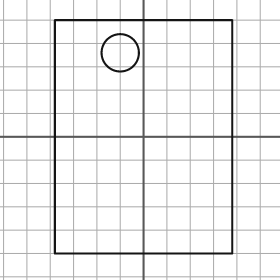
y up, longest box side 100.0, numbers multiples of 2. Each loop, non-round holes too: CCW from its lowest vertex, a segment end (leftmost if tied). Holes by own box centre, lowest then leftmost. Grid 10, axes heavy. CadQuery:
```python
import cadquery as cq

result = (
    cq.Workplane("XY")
    .moveTo(-38.0, -50.0)
    .lineTo(38.0, -50.0)
    .lineTo(38.0, 50.0)
    .lineTo(-38.0, 50.0)
    .close()
    .moveTo(-10.0, 36.0)
    .circle(8.0)
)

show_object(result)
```